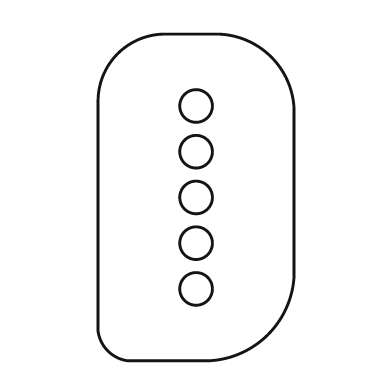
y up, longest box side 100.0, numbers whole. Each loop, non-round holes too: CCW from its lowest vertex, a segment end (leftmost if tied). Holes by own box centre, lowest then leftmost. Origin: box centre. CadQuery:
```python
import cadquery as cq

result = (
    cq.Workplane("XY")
    .moveTo(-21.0, -50.0)
    .lineTo(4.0, -50.0)
    .threePointArc((22.0, -42.0), (30.0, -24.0))
    .lineTo(30.0, 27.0)
    .threePointArc((23.0, 43.0), (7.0, 50.0))
    .lineTo(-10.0, 50.0)
    .threePointArc((-24.0, 44.0), (-30.0, 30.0))
    .lineTo(-30.0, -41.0)
    .threePointArc((-27.0, -47.0), (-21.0, -50.0))
    .close()
    .moveTo(0.0, -28.0)
    .circle(5.0)
    .moveTo(0.0, -14.0)
    .circle(5.0)
    .moveTo(0.0, 0.0)
    .circle(5.0)
    .moveTo(0.0, 14.0)
    .circle(5.0)
    .moveTo(0.0, 28.0)
    .circle(5.0)
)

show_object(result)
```